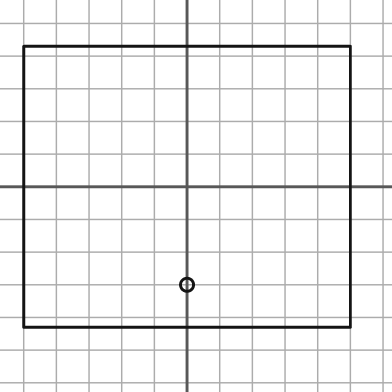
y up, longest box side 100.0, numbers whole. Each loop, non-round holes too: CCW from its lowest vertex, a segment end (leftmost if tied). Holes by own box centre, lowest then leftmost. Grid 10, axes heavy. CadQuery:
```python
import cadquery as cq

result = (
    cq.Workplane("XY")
    .moveTo(-50.0, -43.0)
    .lineTo(50.0, -43.0)
    .lineTo(50.0, 43.0)
    .lineTo(-50.0, 43.0)
    .close()
    .moveTo(0.0, -30.0)
    .circle(2.0)
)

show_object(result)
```